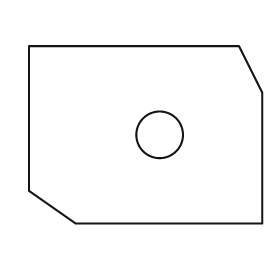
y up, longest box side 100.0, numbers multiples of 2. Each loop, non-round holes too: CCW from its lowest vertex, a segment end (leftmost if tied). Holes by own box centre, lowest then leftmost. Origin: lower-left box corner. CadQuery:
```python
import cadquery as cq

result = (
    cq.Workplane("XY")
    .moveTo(20.0, 0.0)
    .lineTo(100.0, 0.0)
    .lineTo(100.0, 56.0)
    .lineTo(90.0, 76.0)
    .lineTo(0.0, 76.0)
    .lineTo(0.0, 14.0)
    .close()
    .moveTo(56.0, 38.0)
    .circle(10.0)
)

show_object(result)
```